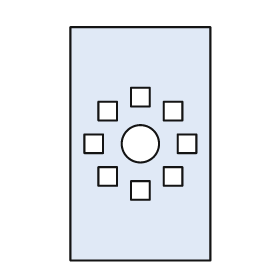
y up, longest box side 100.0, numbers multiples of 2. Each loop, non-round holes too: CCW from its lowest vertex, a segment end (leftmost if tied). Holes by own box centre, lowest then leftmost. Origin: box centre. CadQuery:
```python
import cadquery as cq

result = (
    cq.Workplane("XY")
    .moveTo(-30.0, -50.0)
    .lineTo(30.0, -50.0)
    .lineTo(30.0, 50.0)
    .lineTo(-30.0, 50.0)
    .close()
    .moveTo(-4.0, -24.0)
    .lineTo(4.0, -24.0)
    .lineTo(4.0, -16.0)
    .lineTo(-4.0, -16.0)
    .close()
    .moveTo(-18.0, -18.0)
    .lineTo(-10.0, -18.0)
    .lineTo(-10.0, -10.0)
    .lineTo(-18.0, -10.0)
    .close()
    .moveTo(10.0, -18.0)
    .lineTo(18.0, -18.0)
    .lineTo(18.0, -10.0)
    .lineTo(10.0, -10.0)
    .close()
    .moveTo(-24.0, -4.0)
    .lineTo(-16.0, -4.0)
    .lineTo(-16.0, 4.0)
    .lineTo(-24.0, 4.0)
    .close()
    .moveTo(0.0, 0.0)
    .circle(8.0)
    .moveTo(16.0, -4.0)
    .lineTo(24.0, -4.0)
    .lineTo(24.0, 4.0)
    .lineTo(16.0, 4.0)
    .close()
    .moveTo(-18.0, 10.0)
    .lineTo(-10.0, 10.0)
    .lineTo(-10.0, 18.0)
    .lineTo(-18.0, 18.0)
    .close()
    .moveTo(10.0, 10.0)
    .lineTo(18.0, 10.0)
    .lineTo(18.0, 18.0)
    .lineTo(10.0, 18.0)
    .close()
    .moveTo(-4.0, 16.0)
    .lineTo(4.0, 16.0)
    .lineTo(4.0, 24.0)
    .lineTo(-4.0, 24.0)
    .close()
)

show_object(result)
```